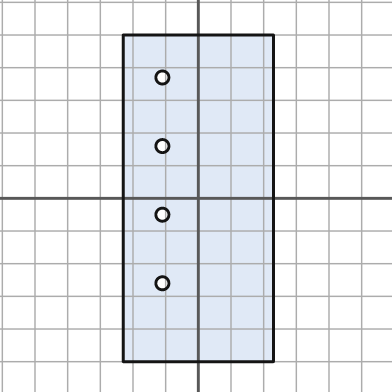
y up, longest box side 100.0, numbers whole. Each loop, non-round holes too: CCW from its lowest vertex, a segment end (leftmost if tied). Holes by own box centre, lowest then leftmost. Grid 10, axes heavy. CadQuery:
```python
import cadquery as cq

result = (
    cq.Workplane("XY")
    .moveTo(-23.0, -50.0)
    .lineTo(23.0, -50.0)
    .lineTo(23.0, 50.0)
    .lineTo(-23.0, 50.0)
    .close()
    .moveTo(-11.0, -26.0)
    .circle(2.0)
    .moveTo(-11.0, -5.0)
    .circle(2.0)
    .moveTo(-11.0, 16.0)
    .circle(2.0)
    .moveTo(-11.0, 37.0)
    .circle(2.0)
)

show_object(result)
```